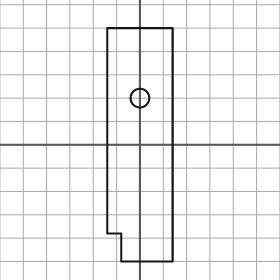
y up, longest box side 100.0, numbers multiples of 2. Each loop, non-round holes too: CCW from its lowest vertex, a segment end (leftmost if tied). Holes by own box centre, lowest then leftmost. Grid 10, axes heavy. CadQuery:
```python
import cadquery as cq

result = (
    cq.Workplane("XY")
    .moveTo(-8.0, -50.0)
    .lineTo(14.0, -50.0)
    .lineTo(14.0, 50.0)
    .lineTo(-14.0, 50.0)
    .lineTo(-14.0, -38.0)
    .lineTo(-8.0, -38.0)
    .close()
    .moveTo(0.0, 20.0)
    .circle(4.0)
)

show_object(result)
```